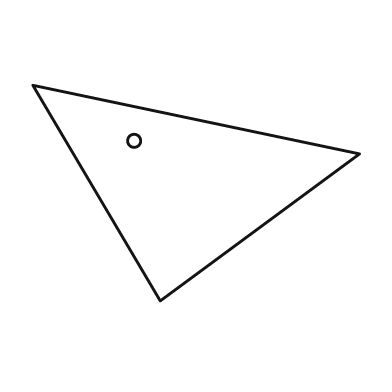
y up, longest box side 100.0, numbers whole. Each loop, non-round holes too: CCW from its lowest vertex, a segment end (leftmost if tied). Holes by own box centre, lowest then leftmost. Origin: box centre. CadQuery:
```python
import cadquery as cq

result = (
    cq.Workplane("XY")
    .moveTo(-11.0, -33.0)
    .lineTo(50.0, 12.0)
    .lineTo(-50.0, 33.0)
    .close()
    .moveTo(-19.0, 16.0)
    .circle(2.0)
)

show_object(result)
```